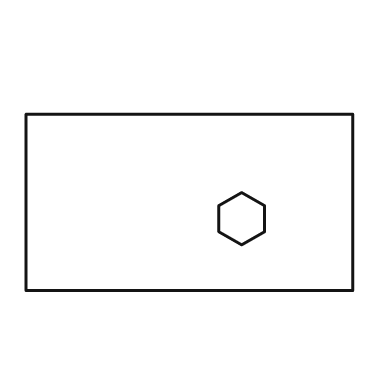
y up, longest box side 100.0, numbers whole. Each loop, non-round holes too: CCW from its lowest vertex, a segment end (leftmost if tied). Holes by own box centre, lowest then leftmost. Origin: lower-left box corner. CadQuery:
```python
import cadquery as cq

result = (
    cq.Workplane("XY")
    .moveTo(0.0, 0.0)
    .lineTo(100.0, 0.0)
    .lineTo(100.0, 54.0)
    .lineTo(0.0, 54.0)
    .close()
    .moveTo(66.0, 14.0)
    .lineTo(73.0, 18.0)
    .lineTo(73.0, 26.0)
    .lineTo(66.0, 30.0)
    .lineTo(59.0, 26.0)
    .lineTo(59.0, 18.0)
    .close()
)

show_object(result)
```